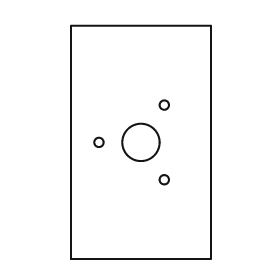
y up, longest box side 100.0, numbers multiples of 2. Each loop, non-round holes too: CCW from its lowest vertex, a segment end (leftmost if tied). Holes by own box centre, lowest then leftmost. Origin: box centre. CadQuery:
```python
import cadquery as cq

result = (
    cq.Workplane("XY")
    .moveTo(-30.0, -50.0)
    .lineTo(30.0, -50.0)
    .lineTo(30.0, 50.0)
    .lineTo(-30.0, 50.0)
    .close()
    .moveTo(10.0, -16.0)
    .circle(2.0)
    .moveTo(-18.0, 0.0)
    .circle(2.0)
    .moveTo(0.0, 0.0)
    .circle(8.0)
    .moveTo(10.0, 16.0)
    .circle(2.0)
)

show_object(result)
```